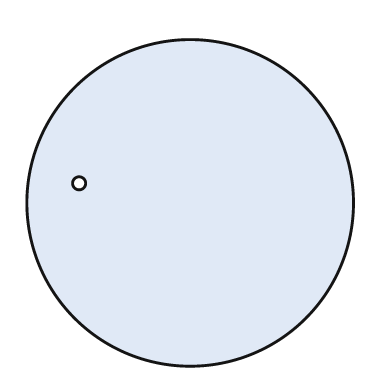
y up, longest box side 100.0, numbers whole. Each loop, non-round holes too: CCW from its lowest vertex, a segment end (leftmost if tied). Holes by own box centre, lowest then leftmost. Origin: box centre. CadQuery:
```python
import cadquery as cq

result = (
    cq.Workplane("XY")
    .moveTo(0.0, 0.0)
    .circle(50.0)
    .moveTo(-34.0, 6.0)
    .circle(2.0)
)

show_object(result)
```